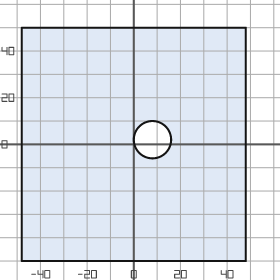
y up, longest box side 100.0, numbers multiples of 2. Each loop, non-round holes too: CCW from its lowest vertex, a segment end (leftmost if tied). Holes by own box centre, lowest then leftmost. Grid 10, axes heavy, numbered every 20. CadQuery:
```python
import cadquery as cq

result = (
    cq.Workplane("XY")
    .moveTo(-48.0, -50.0)
    .lineTo(48.0, -50.0)
    .lineTo(48.0, 50.0)
    .lineTo(-48.0, 50.0)
    .close()
    .moveTo(8.0, 2.0)
    .circle(8.0)
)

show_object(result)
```